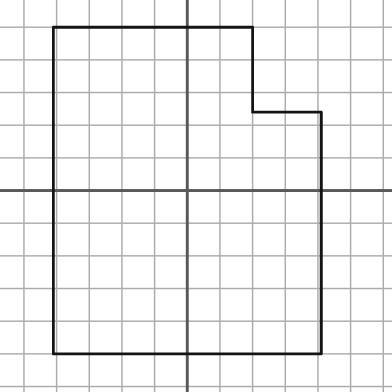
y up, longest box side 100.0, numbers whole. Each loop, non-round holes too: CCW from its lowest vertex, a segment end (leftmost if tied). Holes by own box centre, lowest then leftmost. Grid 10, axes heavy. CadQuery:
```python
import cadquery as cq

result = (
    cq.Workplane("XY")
    .moveTo(-41.0, -50.0)
    .lineTo(41.0, -50.0)
    .lineTo(41.0, 24.0)
    .lineTo(20.0, 24.0)
    .lineTo(20.0, 50.0)
    .lineTo(-41.0, 50.0)
    .close()
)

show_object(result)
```